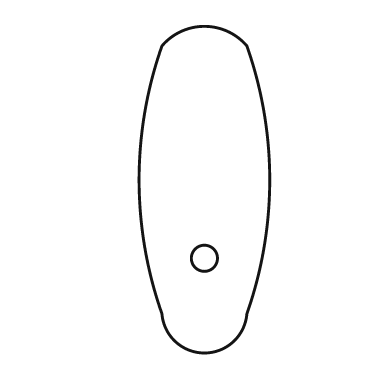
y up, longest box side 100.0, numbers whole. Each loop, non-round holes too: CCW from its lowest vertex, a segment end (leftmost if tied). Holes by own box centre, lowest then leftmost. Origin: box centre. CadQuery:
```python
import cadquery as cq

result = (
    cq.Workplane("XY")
    .moveTo(-13.0, -38.0)
    .threePointArc((0.0, -50.0), (13.0, -38.0))
    .threePointArc((20.0, 3.0), (13.0, 44.0))
    .threePointArc((0.0, 50.0), (-13.0, 44.0))
    .threePointArc((-20.0, 3.0), (-13.0, -38.0))
    .close()
    .moveTo(0.0, -21.0)
    .circle(4.0)
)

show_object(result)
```